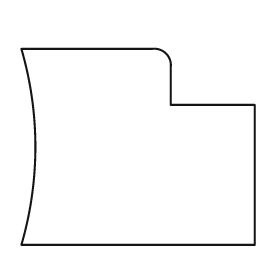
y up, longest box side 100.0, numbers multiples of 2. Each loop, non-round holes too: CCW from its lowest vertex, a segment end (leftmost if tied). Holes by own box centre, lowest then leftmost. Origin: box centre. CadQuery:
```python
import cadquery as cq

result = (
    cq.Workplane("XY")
    .moveTo(-50.0, -42.0)
    .lineTo(50.0, -42.0)
    .lineTo(50.0, 18.0)
    .lineTo(14.0, 18.0)
    .lineTo(14.0, 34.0)
    .threePointArc((12.0, 40.0), (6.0, 42.0))
    .lineTo(-50.0, 42.0)
    .threePointArc((-44.0, 0.0), (-50.0, -42.0))
    .close()
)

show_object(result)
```